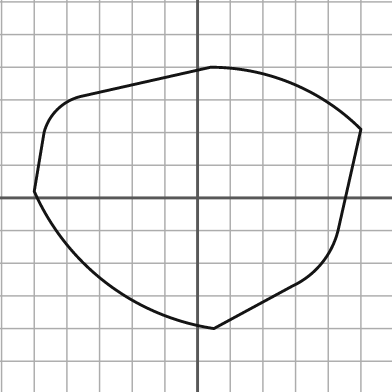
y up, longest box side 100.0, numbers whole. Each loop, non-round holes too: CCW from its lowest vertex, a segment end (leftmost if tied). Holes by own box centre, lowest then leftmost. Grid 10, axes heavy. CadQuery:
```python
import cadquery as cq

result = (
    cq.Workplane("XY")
    .moveTo(5.0, -40.0)
    .lineTo(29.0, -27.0)
    .threePointArc((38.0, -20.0), (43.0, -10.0))
    .lineTo(50.0, 21.0)
    .threePointArc((29.0, 35.0), (4.0, 40.0))
    .lineTo(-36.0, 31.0)
    .threePointArc((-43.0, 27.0), (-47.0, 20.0))
    .lineTo(-50.0, 2.0)
    .threePointArc((-28.0, -26.0), (5.0, -40.0))
    .close()
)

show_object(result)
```